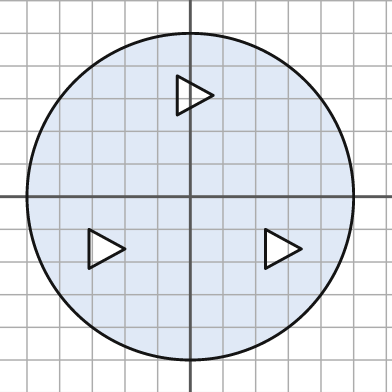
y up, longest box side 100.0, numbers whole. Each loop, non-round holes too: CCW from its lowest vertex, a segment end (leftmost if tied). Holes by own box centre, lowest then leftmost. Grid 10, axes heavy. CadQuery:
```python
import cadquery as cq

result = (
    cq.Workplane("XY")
    .moveTo(0.0, 0.0)
    .circle(50.0)
    .moveTo(-31.0, -22.0)
    .lineTo(-20.0, -16.0)
    .lineTo(-31.0, -10.0)
    .close()
    .moveTo(23.0, -22.0)
    .lineTo(34.0, -16.0)
    .lineTo(23.0, -10.0)
    .close()
    .moveTo(-4.0, 25.0)
    .lineTo(7.0, 31.0)
    .lineTo(-4.0, 37.0)
    .close()
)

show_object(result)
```